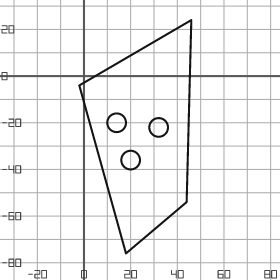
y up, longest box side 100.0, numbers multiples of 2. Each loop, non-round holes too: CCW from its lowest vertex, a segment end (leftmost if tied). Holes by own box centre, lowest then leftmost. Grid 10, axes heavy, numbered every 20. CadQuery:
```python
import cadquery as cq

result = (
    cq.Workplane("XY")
    .moveTo(18.0, -76.0)
    .lineTo(44.0, -54.0)
    .lineTo(46.0, 24.0)
    .lineTo(-2.0, -4.0)
    .close()
    .moveTo(20.0, -36.0)
    .circle(4.0)
    .moveTo(32.0, -22.0)
    .circle(4.0)
    .moveTo(14.0, -20.0)
    .circle(4.0)
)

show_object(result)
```